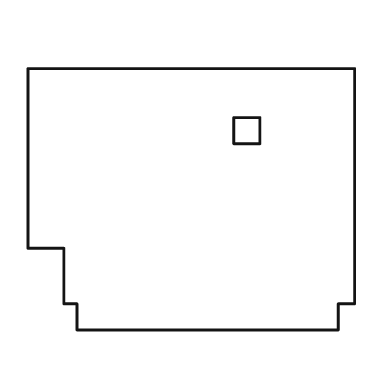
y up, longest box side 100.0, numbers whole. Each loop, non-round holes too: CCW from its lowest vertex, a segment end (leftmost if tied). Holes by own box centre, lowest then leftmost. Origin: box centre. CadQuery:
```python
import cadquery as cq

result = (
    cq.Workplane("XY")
    .moveTo(-35.0, -40.0)
    .lineTo(45.0, -40.0)
    .lineTo(45.0, -32.0)
    .lineTo(50.0, -32.0)
    .lineTo(50.0, 40.0)
    .lineTo(-50.0, 40.0)
    .lineTo(-50.0, -15.0)
    .lineTo(-39.0, -15.0)
    .lineTo(-39.0, -32.0)
    .lineTo(-35.0, -32.0)
    .close()
    .moveTo(13.0, 17.0)
    .lineTo(21.0, 17.0)
    .lineTo(21.0, 25.0)
    .lineTo(13.0, 25.0)
    .close()
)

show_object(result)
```